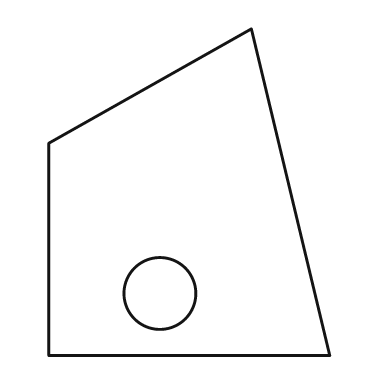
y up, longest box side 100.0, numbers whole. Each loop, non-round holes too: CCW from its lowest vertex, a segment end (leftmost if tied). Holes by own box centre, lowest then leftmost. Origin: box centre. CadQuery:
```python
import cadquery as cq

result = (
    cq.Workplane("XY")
    .moveTo(-43.0, -50.0)
    .lineTo(43.0, -50.0)
    .lineTo(19.0, 50.0)
    .lineTo(-43.0, 15.0)
    .close()
    .moveTo(-9.0, -31.0)
    .circle(11.0)
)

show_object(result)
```